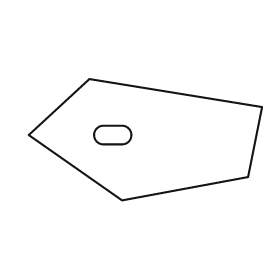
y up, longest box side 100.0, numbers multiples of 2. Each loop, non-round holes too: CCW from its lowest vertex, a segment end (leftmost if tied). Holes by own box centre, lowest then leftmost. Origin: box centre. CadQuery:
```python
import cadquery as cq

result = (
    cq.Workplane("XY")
    .moveTo(-10.0, -26.0)
    .lineTo(44.0, -16.0)
    .lineTo(50.0, 14.0)
    .lineTo(-24.0, 26.0)
    .lineTo(-50.0, 2.0)
    .close()
    .moveTo(-18.0, -2.0)
    .lineTo(-10.0, -2.0)
    .threePointArc((-6.0, 2.0), (-10.0, 6.0))
    .lineTo(-18.0, 6.0)
    .threePointArc((-22.0, 2.0), (-18.0, -2.0))
    .close()
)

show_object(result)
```